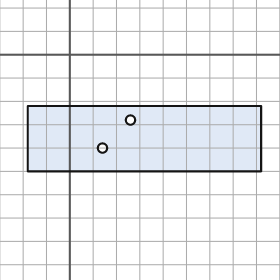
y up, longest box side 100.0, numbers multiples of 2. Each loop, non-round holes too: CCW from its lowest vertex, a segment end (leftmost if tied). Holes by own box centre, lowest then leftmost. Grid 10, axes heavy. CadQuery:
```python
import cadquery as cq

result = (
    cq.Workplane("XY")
    .moveTo(-18.0, -50.0)
    .lineTo(82.0, -50.0)
    .lineTo(82.0, -22.0)
    .lineTo(-18.0, -22.0)
    .close()
    .moveTo(14.0, -40.0)
    .circle(2.0)
    .moveTo(26.0, -28.0)
    .circle(2.0)
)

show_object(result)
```